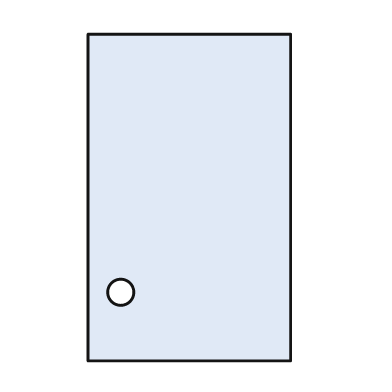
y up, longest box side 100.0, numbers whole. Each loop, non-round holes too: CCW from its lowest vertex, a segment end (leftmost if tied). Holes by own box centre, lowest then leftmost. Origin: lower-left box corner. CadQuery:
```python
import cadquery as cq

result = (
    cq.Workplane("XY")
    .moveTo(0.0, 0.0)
    .lineTo(62.0, 0.0)
    .lineTo(62.0, 100.0)
    .lineTo(0.0, 100.0)
    .close()
    .moveTo(10.0, 21.0)
    .circle(4.0)
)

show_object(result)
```